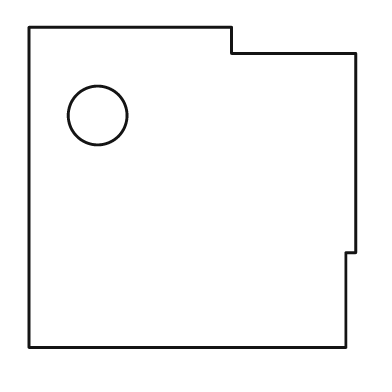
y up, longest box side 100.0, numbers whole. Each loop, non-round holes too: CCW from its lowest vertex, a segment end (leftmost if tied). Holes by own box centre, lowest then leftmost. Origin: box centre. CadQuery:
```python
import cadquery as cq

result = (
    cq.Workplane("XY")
    .moveTo(-50.0, -49.0)
    .lineTo(47.0, -49.0)
    .lineTo(47.0, -20.0)
    .lineTo(50.0, -20.0)
    .lineTo(50.0, 41.0)
    .lineTo(12.0, 41.0)
    .lineTo(12.0, 49.0)
    .lineTo(-50.0, 49.0)
    .close()
    .moveTo(-29.0, 22.0)
    .circle(9.0)
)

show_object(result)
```